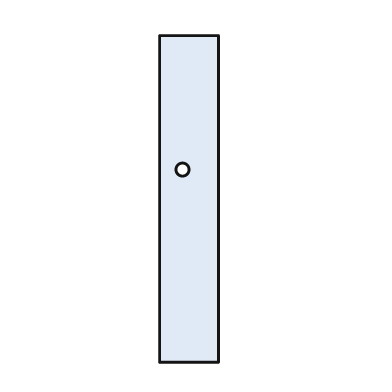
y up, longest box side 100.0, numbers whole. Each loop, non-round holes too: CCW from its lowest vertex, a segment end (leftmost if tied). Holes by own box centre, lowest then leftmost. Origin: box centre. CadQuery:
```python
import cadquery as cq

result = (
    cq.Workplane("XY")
    .moveTo(-9.0, -50.0)
    .lineTo(9.0, -50.0)
    .lineTo(9.0, 50.0)
    .lineTo(-9.0, 50.0)
    .close()
    .moveTo(-2.0, 9.0)
    .circle(2.0)
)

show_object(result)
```